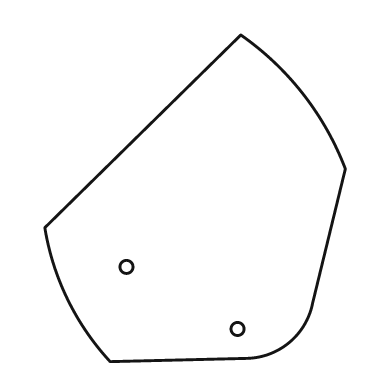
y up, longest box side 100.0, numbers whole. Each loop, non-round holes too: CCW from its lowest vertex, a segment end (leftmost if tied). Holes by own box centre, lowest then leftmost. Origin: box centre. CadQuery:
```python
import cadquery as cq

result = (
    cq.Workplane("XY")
    .moveTo(-26.0, -50.0)
    .lineTo(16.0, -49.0)
    .threePointArc((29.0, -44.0), (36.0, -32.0))
    .lineTo(46.0, 9.0)
    .threePointArc((33.0, 32.0), (14.0, 50.0))
    .lineTo(-46.0, -9.0)
    .threePointArc((-39.0, -31.0), (-26.0, -50.0))
    .close()
    .moveTo(13.0, -40.0)
    .circle(2.0)
    .moveTo(-21.0, -21.0)
    .circle(2.0)
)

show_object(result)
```